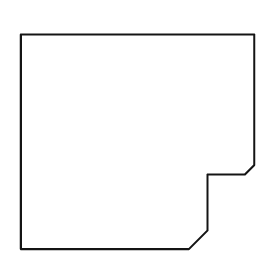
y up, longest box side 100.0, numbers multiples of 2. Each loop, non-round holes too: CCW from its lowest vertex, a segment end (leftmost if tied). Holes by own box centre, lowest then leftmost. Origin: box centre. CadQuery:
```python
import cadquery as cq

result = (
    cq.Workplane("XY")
    .moveTo(-50.0, -46.0)
    .lineTo(22.0, -46.0)
    .lineTo(30.0, -38.0)
    .lineTo(30.0, -14.0)
    .lineTo(46.0, -14.0)
    .lineTo(50.0, -10.0)
    .lineTo(50.0, 46.0)
    .lineTo(-50.0, 46.0)
    .close()
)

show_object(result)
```